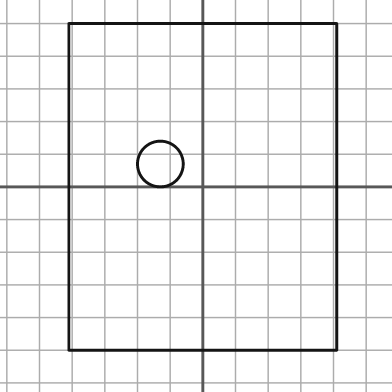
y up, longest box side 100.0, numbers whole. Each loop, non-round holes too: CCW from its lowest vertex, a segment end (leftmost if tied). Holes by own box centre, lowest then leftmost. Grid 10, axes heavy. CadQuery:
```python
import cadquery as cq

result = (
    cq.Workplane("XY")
    .moveTo(-41.0, -50.0)
    .lineTo(41.0, -50.0)
    .lineTo(41.0, 50.0)
    .lineTo(-41.0, 50.0)
    .close()
    .moveTo(-13.0, 7.0)
    .circle(7.0)
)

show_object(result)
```